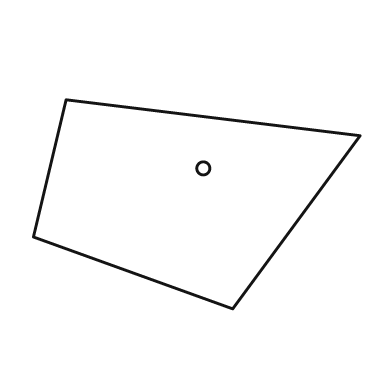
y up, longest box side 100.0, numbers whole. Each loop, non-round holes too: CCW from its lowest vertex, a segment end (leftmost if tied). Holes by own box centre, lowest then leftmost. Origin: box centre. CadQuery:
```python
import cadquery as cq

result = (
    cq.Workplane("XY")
    .moveTo(11.0, -32.0)
    .lineTo(50.0, 21.0)
    .lineTo(-40.0, 32.0)
    .lineTo(-50.0, -10.0)
    .close()
    .moveTo(2.0, 11.0)
    .circle(2.0)
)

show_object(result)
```